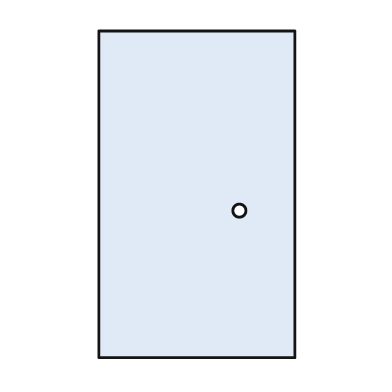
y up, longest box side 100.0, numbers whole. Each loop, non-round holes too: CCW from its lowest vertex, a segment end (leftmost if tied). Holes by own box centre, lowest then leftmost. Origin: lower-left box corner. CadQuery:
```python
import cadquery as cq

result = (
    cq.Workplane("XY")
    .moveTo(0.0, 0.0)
    .lineTo(60.0, 0.0)
    .lineTo(60.0, 100.0)
    .lineTo(0.0, 100.0)
    .close()
    .moveTo(43.0, 45.0)
    .circle(2.0)
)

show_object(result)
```